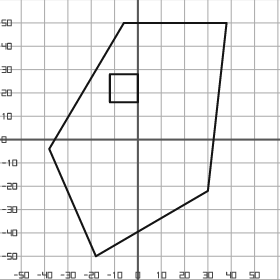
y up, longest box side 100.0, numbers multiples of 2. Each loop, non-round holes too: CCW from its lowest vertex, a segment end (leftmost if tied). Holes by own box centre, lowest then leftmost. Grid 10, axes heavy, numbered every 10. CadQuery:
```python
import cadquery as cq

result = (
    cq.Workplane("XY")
    .moveTo(-18.0, -50.0)
    .lineTo(30.0, -22.0)
    .lineTo(38.0, 50.0)
    .lineTo(-6.0, 50.0)
    .lineTo(-38.0, -4.0)
    .close()
    .moveTo(-12.0, 16.0)
    .lineTo(0.0, 16.0)
    .lineTo(0.0, 28.0)
    .lineTo(-12.0, 28.0)
    .close()
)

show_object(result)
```